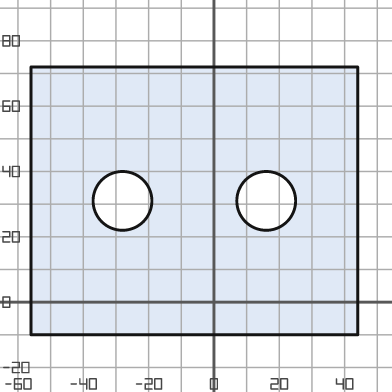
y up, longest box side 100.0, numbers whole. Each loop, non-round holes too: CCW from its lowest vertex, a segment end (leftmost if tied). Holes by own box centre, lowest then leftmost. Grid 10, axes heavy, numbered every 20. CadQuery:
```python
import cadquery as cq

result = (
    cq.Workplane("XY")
    .moveTo(-56.0, -10.0)
    .lineTo(44.0, -10.0)
    .lineTo(44.0, 72.0)
    .lineTo(-56.0, 72.0)
    .close()
    .moveTo(-28.0, 31.0)
    .circle(9.0)
    .moveTo(16.0, 31.0)
    .circle(9.0)
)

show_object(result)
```